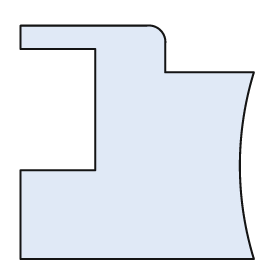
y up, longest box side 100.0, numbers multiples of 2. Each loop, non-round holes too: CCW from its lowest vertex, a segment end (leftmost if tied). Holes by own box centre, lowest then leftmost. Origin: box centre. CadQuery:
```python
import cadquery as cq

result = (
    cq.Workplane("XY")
    .moveTo(-50.0, -50.0)
    .lineTo(50.0, -50.0)
    .threePointArc((44.0, -10.0), (50.0, 30.0))
    .lineTo(12.0, 30.0)
    .lineTo(12.0, 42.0)
    .threePointArc((10.0, 48.0), (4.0, 50.0))
    .lineTo(-50.0, 50.0)
    .lineTo(-50.0, 40.0)
    .lineTo(-18.0, 40.0)
    .lineTo(-18.0, -12.0)
    .lineTo(-50.0, -12.0)
    .close()
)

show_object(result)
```